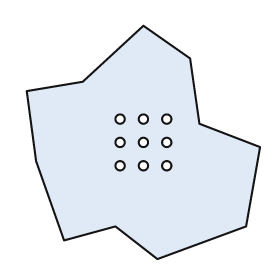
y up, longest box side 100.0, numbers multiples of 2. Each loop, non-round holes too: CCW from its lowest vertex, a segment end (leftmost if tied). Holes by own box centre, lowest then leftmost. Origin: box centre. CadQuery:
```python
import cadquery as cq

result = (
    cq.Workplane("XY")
    .moveTo(6.0, -50.0)
    .lineTo(44.0, -36.0)
    .lineTo(50.0, -2.0)
    .lineTo(24.0, 8.0)
    .lineTo(20.0, 36.0)
    .lineTo(0.0, 50.0)
    .lineTo(-26.0, 26.0)
    .lineTo(-50.0, 22.0)
    .lineTo(-46.0, -8.0)
    .lineTo(-34.0, -42.0)
    .lineTo(-12.0, -36.0)
    .close()
    .moveTo(-10.0, -10.0)
    .circle(2.0)
    .moveTo(0.0, -10.0)
    .circle(2.0)
    .moveTo(10.0, -10.0)
    .circle(2.0)
    .moveTo(-10.0, 0.0)
    .circle(2.0)
    .moveTo(0.0, 0.0)
    .circle(2.0)
    .moveTo(10.0, 0.0)
    .circle(2.0)
    .moveTo(-10.0, 10.0)
    .circle(2.0)
    .moveTo(0.0, 10.0)
    .circle(2.0)
    .moveTo(10.0, 10.0)
    .circle(2.0)
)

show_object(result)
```